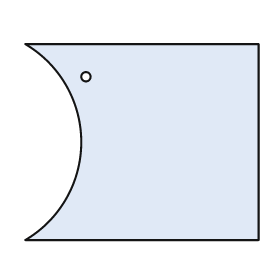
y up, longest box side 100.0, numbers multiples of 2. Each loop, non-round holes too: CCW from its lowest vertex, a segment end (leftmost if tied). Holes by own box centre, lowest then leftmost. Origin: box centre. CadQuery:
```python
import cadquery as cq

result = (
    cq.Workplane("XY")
    .moveTo(-50.0, -42.0)
    .lineTo(50.0, -42.0)
    .lineTo(50.0, 42.0)
    .lineTo(-50.0, 42.0)
    .threePointArc((-26.0, 0.0), (-50.0, -42.0))
    .close()
    .moveTo(-24.0, 28.0)
    .circle(2.0)
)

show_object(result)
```